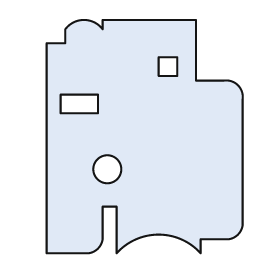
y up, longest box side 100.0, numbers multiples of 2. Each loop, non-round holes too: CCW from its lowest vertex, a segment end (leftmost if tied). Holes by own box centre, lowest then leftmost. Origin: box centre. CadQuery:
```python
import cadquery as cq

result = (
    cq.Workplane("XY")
    .moveTo(-42.0, -50.0)
    .lineTo(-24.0, -50.0)
    .threePointArc((-20.0, -48.0), (-18.0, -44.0))
    .lineTo(-18.0, -30.0)
    .lineTo(-12.0, -30.0)
    .lineTo(-12.0, -50.0)
    .threePointArc((6.0, -42.0), (24.0, -50.0))
    .lineTo(24.0, -44.0)
    .lineTo(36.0, -44.0)
    .threePointArc((40.0, -42.0), (42.0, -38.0))
    .lineTo(42.0, 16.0)
    .threePointArc((40.0, 22.0), (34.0, 24.0))
    .lineTo(22.0, 24.0)
    .lineTo(22.0, 50.0)
    .lineTo(-18.0, 50.0)
    .lineTo(-18.0, 46.0)
    .threePointArc((-26.0, 50.0), (-34.0, 46.0))
    .lineTo(-34.0, 40.0)
    .lineTo(-42.0, 40.0)
    .close()
    .moveTo(-16.0, -14.0)
    .circle(6.0)
    .moveTo(-36.0, 10.0)
    .lineTo(-20.0, 10.0)
    .lineTo(-20.0, 18.0)
    .lineTo(-36.0, 18.0)
    .close()
    .moveTo(6.0, 26.0)
    .lineTo(14.0, 26.0)
    .lineTo(14.0, 34.0)
    .lineTo(6.0, 34.0)
    .close()
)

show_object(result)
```